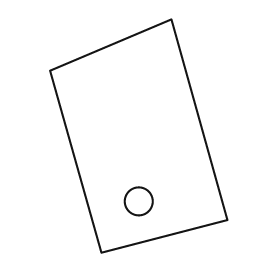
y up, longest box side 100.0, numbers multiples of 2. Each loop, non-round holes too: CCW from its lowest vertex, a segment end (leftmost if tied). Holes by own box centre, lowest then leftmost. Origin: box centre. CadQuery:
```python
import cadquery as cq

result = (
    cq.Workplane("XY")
    .moveTo(-16.0, -50.0)
    .lineTo(38.0, -36.0)
    .lineTo(14.0, 50.0)
    .lineTo(-38.0, 28.0)
    .close()
    .moveTo(0.0, -28.0)
    .circle(6.0)
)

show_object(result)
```